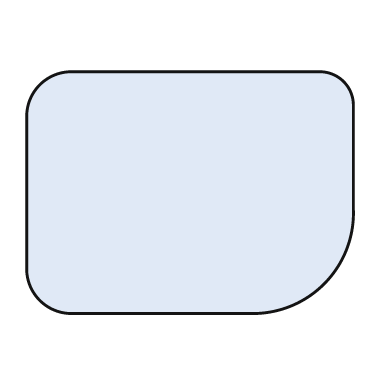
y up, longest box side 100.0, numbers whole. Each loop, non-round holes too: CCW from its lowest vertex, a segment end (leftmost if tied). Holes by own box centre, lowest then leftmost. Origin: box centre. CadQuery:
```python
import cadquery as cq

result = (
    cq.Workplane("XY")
    .moveTo(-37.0, -37.0)
    .lineTo(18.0, -37.0)
    .threePointArc((41.0, -28.0), (50.0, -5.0))
    .lineTo(50.0, 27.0)
    .threePointArc((47.0, 34.0), (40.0, 37.0))
    .lineTo(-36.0, 37.0)
    .threePointArc((-46.0, 33.0), (-50.0, 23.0))
    .lineTo(-50.0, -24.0)
    .threePointArc((-46.0, -33.0), (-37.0, -37.0))
    .close()
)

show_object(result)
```